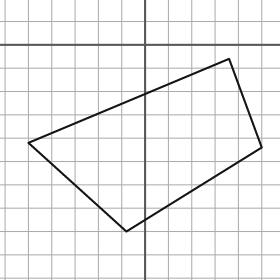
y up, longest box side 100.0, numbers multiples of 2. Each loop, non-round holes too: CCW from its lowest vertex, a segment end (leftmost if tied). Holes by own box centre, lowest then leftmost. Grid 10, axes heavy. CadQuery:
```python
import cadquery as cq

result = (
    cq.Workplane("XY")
    .moveTo(-8.0, -80.0)
    .lineTo(50.0, -44.0)
    .lineTo(36.0, -6.0)
    .lineTo(-50.0, -42.0)
    .close()
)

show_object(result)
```